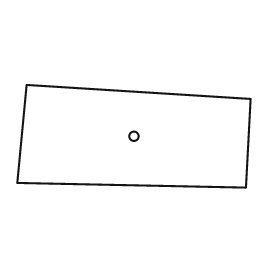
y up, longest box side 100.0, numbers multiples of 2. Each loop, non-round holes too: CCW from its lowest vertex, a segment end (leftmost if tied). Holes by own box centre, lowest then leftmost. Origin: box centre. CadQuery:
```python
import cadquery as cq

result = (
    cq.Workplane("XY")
    .moveTo(48.0, -22.0)
    .lineTo(50.0, 16.0)
    .lineTo(-46.0, 22.0)
    .lineTo(-50.0, -20.0)
    .close()
    .moveTo(0.0, 0.0)
    .circle(2.0)
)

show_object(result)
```